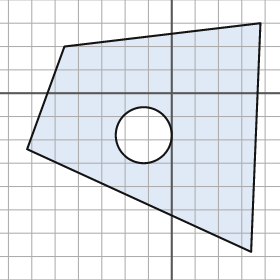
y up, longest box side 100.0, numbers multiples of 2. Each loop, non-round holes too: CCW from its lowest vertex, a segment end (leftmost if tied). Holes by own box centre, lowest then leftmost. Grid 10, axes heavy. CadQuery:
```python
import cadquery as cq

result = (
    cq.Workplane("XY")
    .moveTo(34.0, -68.0)
    .lineTo(38.0, 30.0)
    .lineTo(-46.0, 20.0)
    .lineTo(-62.0, -24.0)
    .close()
    .moveTo(-12.0, -18.0)
    .circle(12.0)
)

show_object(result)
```